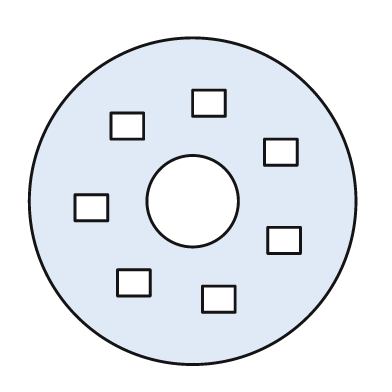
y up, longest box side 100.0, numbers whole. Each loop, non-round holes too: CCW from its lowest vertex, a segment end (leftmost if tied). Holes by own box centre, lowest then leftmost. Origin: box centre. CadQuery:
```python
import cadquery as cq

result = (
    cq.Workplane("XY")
    .moveTo(0.0, 0.0)
    .circle(50.0)
    .moveTo(3.0, -34.0)
    .lineTo(13.0, -34.0)
    .lineTo(13.0, -26.0)
    .lineTo(3.0, -26.0)
    .close()
    .moveTo(-23.0, -29.0)
    .lineTo(-13.0, -29.0)
    .lineTo(-13.0, -21.0)
    .lineTo(-23.0, -21.0)
    .close()
    .moveTo(23.0, -16.0)
    .lineTo(33.0, -16.0)
    .lineTo(33.0, -8.0)
    .lineTo(23.0, -8.0)
    .close()
    .moveTo(-36.0, -6.0)
    .lineTo(-26.0, -6.0)
    .lineTo(-26.0, 2.0)
    .lineTo(-36.0, 2.0)
    .close()
    .moveTo(0.0, 0.0)
    .circle(14.0)
    .moveTo(22.0, 11.0)
    .lineTo(32.0, 11.0)
    .lineTo(32.0, 19.0)
    .lineTo(22.0, 19.0)
    .close()
    .moveTo(-25.0, 19.0)
    .lineTo(-15.0, 19.0)
    .lineTo(-15.0, 27.0)
    .lineTo(-25.0, 27.0)
    .close()
    .moveTo(0.0, 26.0)
    .lineTo(10.0, 26.0)
    .lineTo(10.0, 34.0)
    .lineTo(0.0, 34.0)
    .close()
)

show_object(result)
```